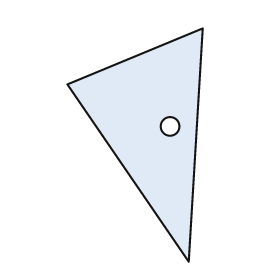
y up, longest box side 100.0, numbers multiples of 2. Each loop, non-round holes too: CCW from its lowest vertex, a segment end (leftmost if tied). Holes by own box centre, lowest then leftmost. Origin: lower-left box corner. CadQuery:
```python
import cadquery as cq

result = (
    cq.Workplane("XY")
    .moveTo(52.0, 0.0)
    .lineTo(58.0, 100.0)
    .lineTo(0.0, 76.0)
    .close()
    .moveTo(44.0, 58.0)
    .circle(4.0)
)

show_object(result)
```